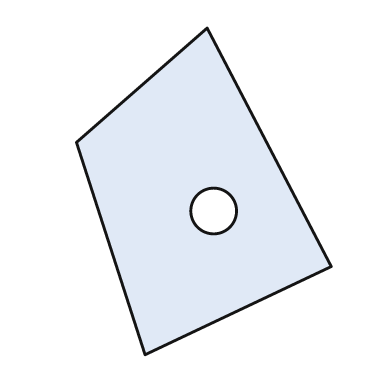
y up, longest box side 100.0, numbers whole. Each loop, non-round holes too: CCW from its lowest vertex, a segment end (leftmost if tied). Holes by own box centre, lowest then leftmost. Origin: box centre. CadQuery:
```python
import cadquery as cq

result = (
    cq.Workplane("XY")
    .moveTo(-18.0, -50.0)
    .lineTo(39.0, -23.0)
    .lineTo(1.0, 50.0)
    .lineTo(-39.0, 15.0)
    .close()
    .moveTo(3.0, -6.0)
    .circle(7.0)
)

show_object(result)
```